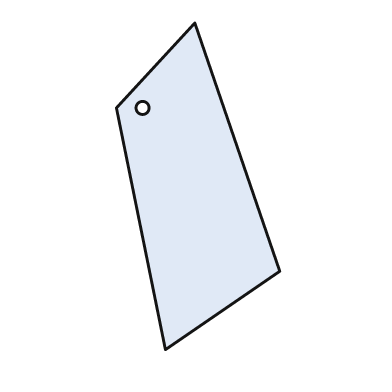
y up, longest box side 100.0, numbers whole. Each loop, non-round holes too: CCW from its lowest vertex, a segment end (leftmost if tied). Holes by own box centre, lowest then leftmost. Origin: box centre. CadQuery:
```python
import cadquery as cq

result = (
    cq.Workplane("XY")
    .moveTo(-10.0, -50.0)
    .lineTo(25.0, -26.0)
    .lineTo(-1.0, 50.0)
    .lineTo(-25.0, 24.0)
    .close()
    .moveTo(-17.0, 24.0)
    .circle(2.0)
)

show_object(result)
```